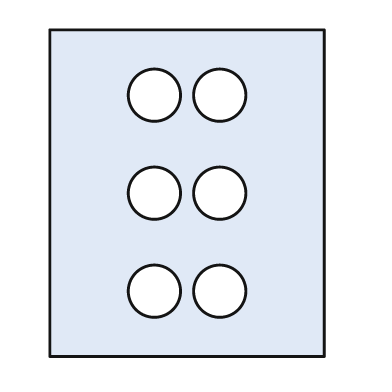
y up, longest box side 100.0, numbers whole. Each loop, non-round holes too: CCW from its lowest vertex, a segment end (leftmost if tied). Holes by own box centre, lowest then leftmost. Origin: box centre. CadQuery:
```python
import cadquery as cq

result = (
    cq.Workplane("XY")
    .moveTo(-42.0, -50.0)
    .lineTo(42.0, -50.0)
    .lineTo(42.0, 50.0)
    .lineTo(-42.0, 50.0)
    .close()
    .moveTo(-10.0, -30.0)
    .circle(8.0)
    .moveTo(10.0, -30.0)
    .circle(8.0)
    .moveTo(-10.0, 0.0)
    .circle(8.0)
    .moveTo(10.0, 0.0)
    .circle(8.0)
    .moveTo(-10.0, 30.0)
    .circle(8.0)
    .moveTo(10.0, 30.0)
    .circle(8.0)
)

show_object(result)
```